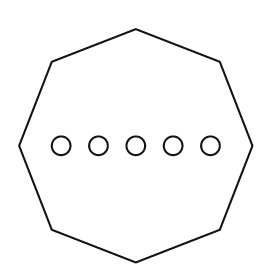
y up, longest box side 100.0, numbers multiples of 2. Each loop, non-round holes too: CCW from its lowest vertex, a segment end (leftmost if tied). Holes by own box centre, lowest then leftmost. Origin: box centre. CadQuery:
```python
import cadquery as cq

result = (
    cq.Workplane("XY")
    .moveTo(0.0, -50.0)
    .lineTo(36.0, -36.0)
    .lineTo(50.0, 0.0)
    .lineTo(36.0, 36.0)
    .lineTo(0.0, 50.0)
    .lineTo(-36.0, 36.0)
    .lineTo(-50.0, 0.0)
    .lineTo(-36.0, -36.0)
    .close()
    .moveTo(-32.0, 0.0)
    .circle(4.0)
    .moveTo(-16.0, 0.0)
    .circle(4.0)
    .moveTo(0.0, 0.0)
    .circle(4.0)
    .moveTo(16.0, 0.0)
    .circle(4.0)
    .moveTo(32.0, 0.0)
    .circle(4.0)
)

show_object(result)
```